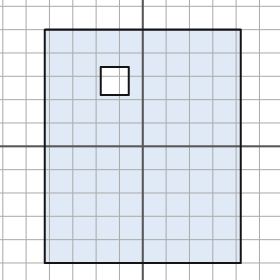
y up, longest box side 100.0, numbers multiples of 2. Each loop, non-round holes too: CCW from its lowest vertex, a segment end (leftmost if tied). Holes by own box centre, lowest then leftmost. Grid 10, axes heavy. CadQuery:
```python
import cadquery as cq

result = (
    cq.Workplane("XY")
    .moveTo(-42.0, -50.0)
    .lineTo(42.0, -50.0)
    .lineTo(42.0, 50.0)
    .lineTo(-42.0, 50.0)
    .close()
    .moveTo(-18.0, 22.0)
    .lineTo(-6.0, 22.0)
    .lineTo(-6.0, 34.0)
    .lineTo(-18.0, 34.0)
    .close()
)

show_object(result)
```